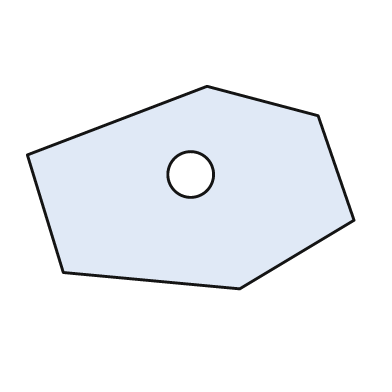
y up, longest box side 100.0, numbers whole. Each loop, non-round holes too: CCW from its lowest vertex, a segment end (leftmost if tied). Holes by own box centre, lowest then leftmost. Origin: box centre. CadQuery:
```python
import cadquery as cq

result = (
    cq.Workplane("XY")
    .moveTo(15.0, -31.0)
    .lineTo(50.0, -10.0)
    .lineTo(39.0, 22.0)
    .lineTo(5.0, 31.0)
    .lineTo(-50.0, 10.0)
    .lineTo(-39.0, -26.0)
    .close()
    .moveTo(0.0, 4.0)
    .circle(7.0)
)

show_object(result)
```